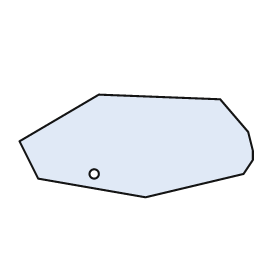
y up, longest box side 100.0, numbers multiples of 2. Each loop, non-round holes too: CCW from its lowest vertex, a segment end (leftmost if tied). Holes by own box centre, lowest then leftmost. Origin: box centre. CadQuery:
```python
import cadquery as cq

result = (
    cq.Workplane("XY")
    .moveTo(4.0, -22.0)
    .lineTo(46.0, -12.0)
    .lineTo(50.0, -6.0)
    .lineTo(50.0, -2.0)
    .lineTo(48.0, 6.0)
    .lineTo(36.0, 20.0)
    .lineTo(-16.0, 22.0)
    .lineTo(-50.0, 2.0)
    .lineTo(-42.0, -14.0)
    .close()
    .moveTo(-18.0, -12.0)
    .circle(2.0)
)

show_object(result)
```